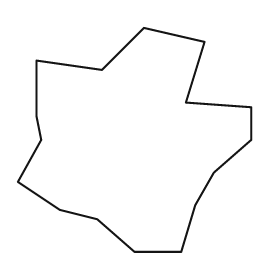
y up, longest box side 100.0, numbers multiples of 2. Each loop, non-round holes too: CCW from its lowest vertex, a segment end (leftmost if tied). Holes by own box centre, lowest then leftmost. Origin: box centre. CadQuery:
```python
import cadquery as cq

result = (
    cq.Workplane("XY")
    .moveTo(0.0, -48.0)
    .lineTo(20.0, -48.0)
    .lineTo(26.0, -28.0)
    .lineTo(34.0, -14.0)
    .lineTo(50.0, 0.0)
    .lineTo(50.0, 14.0)
    .lineTo(22.0, 16.0)
    .lineTo(30.0, 42.0)
    .lineTo(4.0, 48.0)
    .lineTo(-14.0, 30.0)
    .lineTo(-42.0, 34.0)
    .lineTo(-42.0, 10.0)
    .lineTo(-40.0, 0.0)
    .lineTo(-50.0, -18.0)
    .lineTo(-32.0, -30.0)
    .lineTo(-16.0, -34.0)
    .close()
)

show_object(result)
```